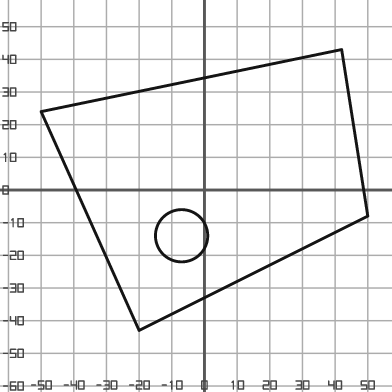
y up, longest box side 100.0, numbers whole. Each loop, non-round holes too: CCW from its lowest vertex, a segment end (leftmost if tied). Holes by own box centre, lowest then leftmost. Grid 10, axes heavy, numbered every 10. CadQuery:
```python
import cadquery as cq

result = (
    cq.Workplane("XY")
    .moveTo(-20.0, -43.0)
    .lineTo(50.0, -8.0)
    .lineTo(42.0, 43.0)
    .lineTo(-50.0, 24.0)
    .close()
    .moveTo(-7.0, -14.0)
    .circle(8.0)
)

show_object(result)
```